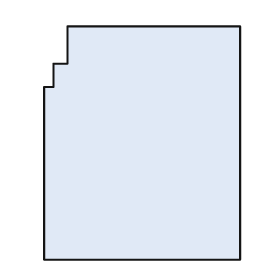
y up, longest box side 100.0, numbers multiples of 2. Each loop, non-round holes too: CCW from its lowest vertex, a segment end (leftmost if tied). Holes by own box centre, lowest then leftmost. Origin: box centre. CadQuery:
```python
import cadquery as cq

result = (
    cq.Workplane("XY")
    .moveTo(-42.0, -50.0)
    .lineTo(42.0, -50.0)
    .lineTo(42.0, 50.0)
    .lineTo(-32.0, 50.0)
    .lineTo(-32.0, 34.0)
    .lineTo(-38.0, 34.0)
    .lineTo(-38.0, 24.0)
    .lineTo(-42.0, 24.0)
    .close()
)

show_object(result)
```